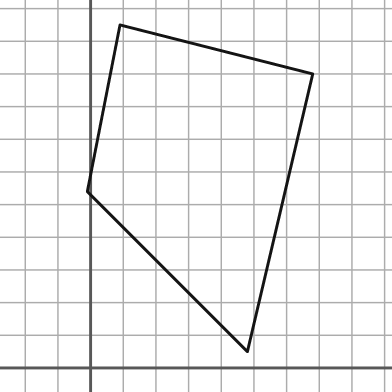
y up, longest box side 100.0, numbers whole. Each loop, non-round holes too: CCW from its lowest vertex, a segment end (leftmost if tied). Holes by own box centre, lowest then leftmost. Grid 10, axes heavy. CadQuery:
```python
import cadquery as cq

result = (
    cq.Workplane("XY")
    .moveTo(48.0, 5.0)
    .lineTo(68.0, 90.0)
    .lineTo(9.0, 105.0)
    .lineTo(-1.0, 54.0)
    .close()
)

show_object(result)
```